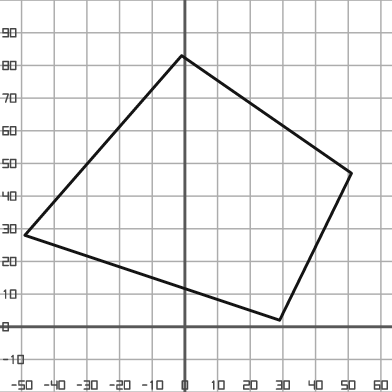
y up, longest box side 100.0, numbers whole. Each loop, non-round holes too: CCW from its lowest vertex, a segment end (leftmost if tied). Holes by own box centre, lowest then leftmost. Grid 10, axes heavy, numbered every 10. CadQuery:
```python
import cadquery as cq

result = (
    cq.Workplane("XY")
    .moveTo(29.0, 2.0)
    .lineTo(51.0, 47.0)
    .lineTo(-1.0, 83.0)
    .lineTo(-49.0, 28.0)
    .close()
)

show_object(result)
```